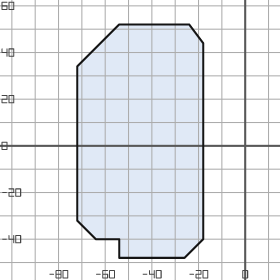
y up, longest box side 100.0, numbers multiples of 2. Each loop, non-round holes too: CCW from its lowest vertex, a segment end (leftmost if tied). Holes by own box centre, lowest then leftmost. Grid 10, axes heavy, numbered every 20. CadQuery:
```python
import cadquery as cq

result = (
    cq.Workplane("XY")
    .moveTo(-54.0, -48.0)
    .lineTo(-26.0, -48.0)
    .lineTo(-18.0, -40.0)
    .lineTo(-18.0, 44.0)
    .lineTo(-24.0, 52.0)
    .lineTo(-54.0, 52.0)
    .lineTo(-72.0, 34.0)
    .lineTo(-72.0, -32.0)
    .lineTo(-64.0, -40.0)
    .lineTo(-54.0, -40.0)
    .close()
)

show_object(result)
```